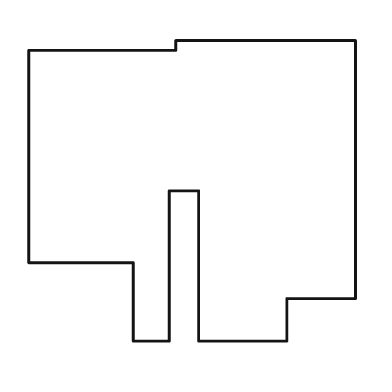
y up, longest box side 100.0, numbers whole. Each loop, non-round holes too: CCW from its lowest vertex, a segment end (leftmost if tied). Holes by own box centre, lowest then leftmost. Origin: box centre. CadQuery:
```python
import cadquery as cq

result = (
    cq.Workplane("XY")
    .moveTo(-18.0, -46.0)
    .lineTo(-7.0, -46.0)
    .lineTo(-7.0, 0.0)
    .lineTo(2.0, 0.0)
    .lineTo(2.0, -46.0)
    .lineTo(29.0, -46.0)
    .lineTo(29.0, -33.0)
    .lineTo(50.0, -33.0)
    .lineTo(50.0, 46.0)
    .lineTo(-5.0, 46.0)
    .lineTo(-5.0, 43.0)
    .lineTo(-50.0, 43.0)
    .lineTo(-50.0, -22.0)
    .lineTo(-18.0, -22.0)
    .close()
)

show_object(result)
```